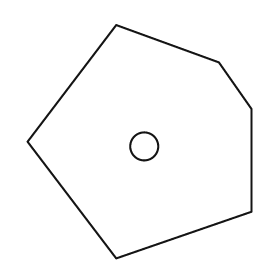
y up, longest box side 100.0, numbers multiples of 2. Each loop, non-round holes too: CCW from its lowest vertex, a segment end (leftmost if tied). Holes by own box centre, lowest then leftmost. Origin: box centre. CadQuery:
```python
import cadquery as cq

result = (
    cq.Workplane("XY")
    .moveTo(-10.0, -50.0)
    .lineTo(48.0, -30.0)
    .lineTo(48.0, 14.0)
    .lineTo(34.0, 34.0)
    .lineTo(-10.0, 50.0)
    .lineTo(-48.0, 0.0)
    .close()
    .moveTo(2.0, -2.0)
    .circle(6.0)
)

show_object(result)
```